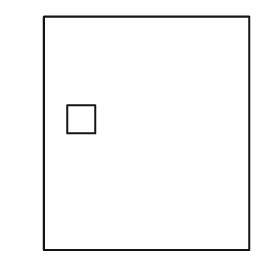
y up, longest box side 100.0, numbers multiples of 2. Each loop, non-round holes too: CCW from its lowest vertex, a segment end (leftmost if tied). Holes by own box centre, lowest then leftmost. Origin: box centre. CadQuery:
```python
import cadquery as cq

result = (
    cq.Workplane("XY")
    .moveTo(-44.0, -50.0)
    .lineTo(44.0, -50.0)
    .lineTo(44.0, 50.0)
    .lineTo(-44.0, 50.0)
    .close()
    .moveTo(-34.0, 0.0)
    .lineTo(-22.0, 0.0)
    .lineTo(-22.0, 12.0)
    .lineTo(-34.0, 12.0)
    .close()
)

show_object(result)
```